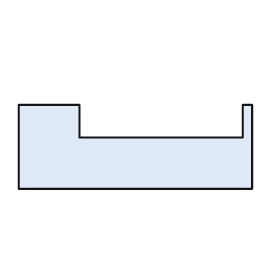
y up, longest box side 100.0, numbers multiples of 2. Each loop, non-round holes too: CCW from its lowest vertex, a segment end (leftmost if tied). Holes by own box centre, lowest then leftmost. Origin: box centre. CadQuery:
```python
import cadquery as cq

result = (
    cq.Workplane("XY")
    .moveTo(-50.0, -18.0)
    .lineTo(50.0, -18.0)
    .lineTo(50.0, 18.0)
    .lineTo(46.0, 18.0)
    .lineTo(46.0, 4.0)
    .lineTo(-24.0, 4.0)
    .lineTo(-24.0, 18.0)
    .lineTo(-50.0, 18.0)
    .close()
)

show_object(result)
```